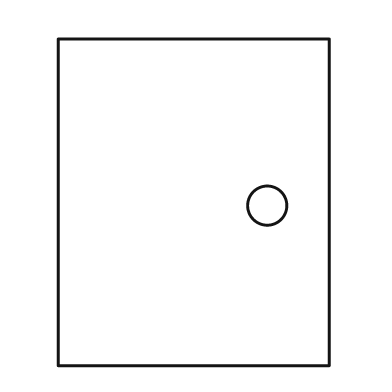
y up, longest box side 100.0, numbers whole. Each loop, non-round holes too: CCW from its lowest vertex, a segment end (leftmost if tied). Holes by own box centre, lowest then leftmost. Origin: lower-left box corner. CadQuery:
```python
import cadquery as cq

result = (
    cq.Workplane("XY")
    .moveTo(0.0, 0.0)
    .lineTo(83.0, 0.0)
    .lineTo(83.0, 100.0)
    .lineTo(0.0, 100.0)
    .close()
    .moveTo(64.0, 49.0)
    .circle(6.0)
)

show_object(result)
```